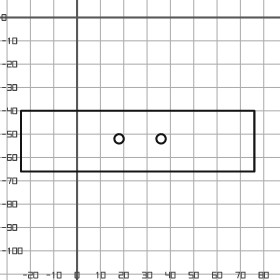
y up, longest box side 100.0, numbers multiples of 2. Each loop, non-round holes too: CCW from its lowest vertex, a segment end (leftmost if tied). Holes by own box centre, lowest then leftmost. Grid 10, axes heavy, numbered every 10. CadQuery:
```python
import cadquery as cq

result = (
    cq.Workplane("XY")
    .moveTo(-24.0, -66.0)
    .lineTo(76.0, -66.0)
    .lineTo(76.0, -40.0)
    .lineTo(-24.0, -40.0)
    .close()
    .moveTo(18.0, -52.0)
    .circle(2.0)
    .moveTo(36.0, -52.0)
    .circle(2.0)
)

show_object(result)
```